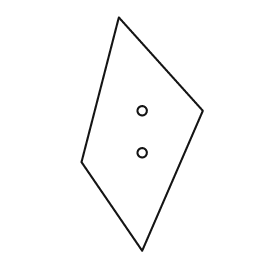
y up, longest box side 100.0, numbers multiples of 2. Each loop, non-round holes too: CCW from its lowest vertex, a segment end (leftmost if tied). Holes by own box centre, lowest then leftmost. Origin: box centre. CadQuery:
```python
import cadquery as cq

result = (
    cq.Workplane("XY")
    .moveTo(0.0, -50.0)
    .lineTo(26.0, 10.0)
    .lineTo(-10.0, 50.0)
    .lineTo(-26.0, -12.0)
    .close()
    .moveTo(0.0, -8.0)
    .circle(2.0)
    .moveTo(0.0, 10.0)
    .circle(2.0)
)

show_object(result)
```